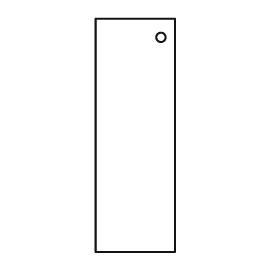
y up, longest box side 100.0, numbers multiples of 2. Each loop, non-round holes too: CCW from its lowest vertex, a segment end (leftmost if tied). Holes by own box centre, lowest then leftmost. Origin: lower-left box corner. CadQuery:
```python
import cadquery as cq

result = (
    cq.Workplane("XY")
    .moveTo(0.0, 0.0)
    .lineTo(34.0, 0.0)
    .lineTo(34.0, 100.0)
    .lineTo(0.0, 100.0)
    .close()
    .moveTo(28.0, 92.0)
    .circle(2.0)
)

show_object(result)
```